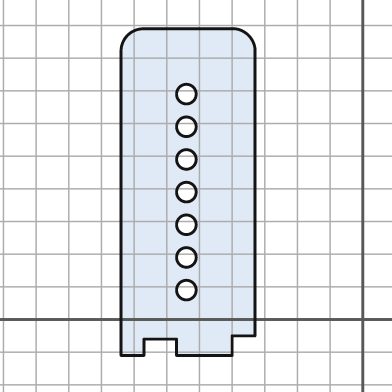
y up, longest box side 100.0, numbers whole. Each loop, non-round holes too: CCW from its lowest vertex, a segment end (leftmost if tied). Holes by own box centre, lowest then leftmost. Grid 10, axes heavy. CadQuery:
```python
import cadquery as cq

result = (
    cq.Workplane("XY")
    .moveTo(-74.0, -11.0)
    .lineTo(-67.0, -11.0)
    .lineTo(-67.0, -6.0)
    .lineTo(-57.0, -6.0)
    .lineTo(-57.0, -11.0)
    .lineTo(-40.0, -11.0)
    .lineTo(-40.0, -5.0)
    .lineTo(-33.0, -5.0)
    .lineTo(-33.0, 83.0)
    .threePointArc((-35.0, 87.0), (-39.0, 89.0))
    .lineTo(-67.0, 89.0)
    .threePointArc((-72.0, 87.0), (-74.0, 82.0))
    .close()
    .moveTo(-54.0, 9.0)
    .circle(3.0)
    .moveTo(-54.0, 19.0)
    .circle(3.0)
    .moveTo(-54.0, 29.0)
    .circle(3.0)
    .moveTo(-54.0, 39.0)
    .circle(3.0)
    .moveTo(-54.0, 49.0)
    .circle(3.0)
    .moveTo(-54.0, 59.0)
    .circle(3.0)
    .moveTo(-54.0, 69.0)
    .circle(3.0)
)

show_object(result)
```